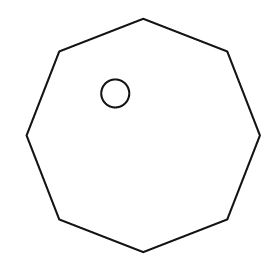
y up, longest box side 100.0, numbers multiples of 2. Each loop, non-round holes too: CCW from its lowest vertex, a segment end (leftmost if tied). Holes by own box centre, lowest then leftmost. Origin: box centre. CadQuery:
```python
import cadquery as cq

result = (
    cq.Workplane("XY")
    .moveTo(0.0, -50.0)
    .lineTo(36.0, -36.0)
    .lineTo(50.0, 0.0)
    .lineTo(36.0, 36.0)
    .lineTo(0.0, 50.0)
    .lineTo(-36.0, 36.0)
    .lineTo(-50.0, 0.0)
    .lineTo(-36.0, -36.0)
    .close()
    .moveTo(-12.0, 18.0)
    .circle(6.0)
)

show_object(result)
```